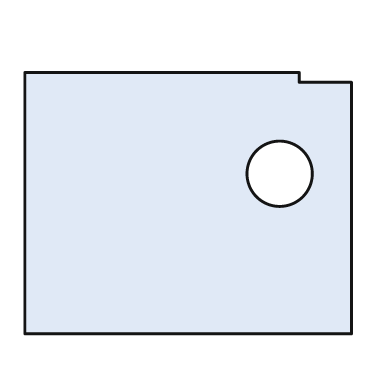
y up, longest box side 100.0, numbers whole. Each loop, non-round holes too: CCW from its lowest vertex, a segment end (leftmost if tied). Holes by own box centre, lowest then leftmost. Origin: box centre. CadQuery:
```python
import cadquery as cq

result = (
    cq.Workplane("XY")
    .moveTo(-50.0, -40.0)
    .lineTo(50.0, -40.0)
    .lineTo(50.0, 37.0)
    .lineTo(34.0, 37.0)
    .lineTo(34.0, 40.0)
    .lineTo(-50.0, 40.0)
    .close()
    .moveTo(28.0, 9.0)
    .circle(10.0)
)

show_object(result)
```